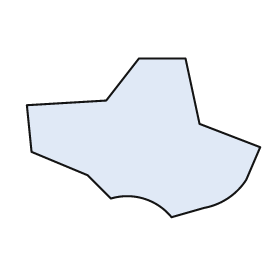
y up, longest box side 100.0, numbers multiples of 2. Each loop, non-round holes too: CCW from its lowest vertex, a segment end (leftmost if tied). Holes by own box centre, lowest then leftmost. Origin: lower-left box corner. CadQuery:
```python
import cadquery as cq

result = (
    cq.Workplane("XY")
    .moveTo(62.0, 0.0)
    .lineTo(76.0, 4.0)
    .threePointArc((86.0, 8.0), (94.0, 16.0))
    .lineTo(100.0, 30.0)
    .lineTo(74.0, 40.0)
    .lineTo(68.0, 68.0)
    .lineTo(48.0, 68.0)
    .lineTo(34.0, 50.0)
    .lineTo(0.0, 48.0)
    .lineTo(2.0, 28.0)
    .lineTo(26.0, 18.0)
    .lineTo(36.0, 8.0)
    .threePointArc((50.0, 8.0), (62.0, 0.0))
    .close()
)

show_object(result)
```